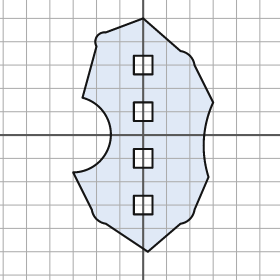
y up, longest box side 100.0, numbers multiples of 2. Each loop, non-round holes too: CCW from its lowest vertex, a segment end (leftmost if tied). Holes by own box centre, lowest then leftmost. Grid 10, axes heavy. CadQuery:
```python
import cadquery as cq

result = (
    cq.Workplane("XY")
    .moveTo(2.0, -50.0)
    .lineTo(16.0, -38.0)
    .threePointArc((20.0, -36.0), (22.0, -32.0))
    .lineTo(28.0, -18.0)
    .threePointArc((26.0, -2.0), (30.0, 14.0))
    .lineTo(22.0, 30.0)
    .threePointArc((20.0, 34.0), (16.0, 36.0))
    .lineTo(0.0, 50.0)
    .lineTo(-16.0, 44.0)
    .threePointArc((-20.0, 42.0), (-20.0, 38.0))
    .lineTo(-26.0, 16.0)
    .threePointArc((-14.0, -2.0), (-30.0, -16.0))
    .lineTo(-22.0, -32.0)
    .threePointArc((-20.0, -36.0), (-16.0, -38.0))
    .close()
    .moveTo(-4.0, -34.0)
    .lineTo(4.0, -34.0)
    .lineTo(4.0, -26.0)
    .lineTo(-4.0, -26.0)
    .close()
    .moveTo(-4.0, -14.0)
    .lineTo(4.0, -14.0)
    .lineTo(4.0, -6.0)
    .lineTo(-4.0, -6.0)
    .close()
    .moveTo(-4.0, 6.0)
    .lineTo(4.0, 6.0)
    .lineTo(4.0, 14.0)
    .lineTo(-4.0, 14.0)
    .close()
    .moveTo(-4.0, 26.0)
    .lineTo(4.0, 26.0)
    .lineTo(4.0, 34.0)
    .lineTo(-4.0, 34.0)
    .close()
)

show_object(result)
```